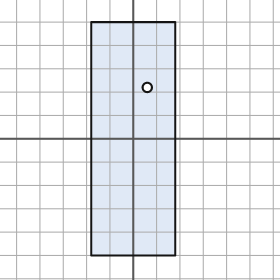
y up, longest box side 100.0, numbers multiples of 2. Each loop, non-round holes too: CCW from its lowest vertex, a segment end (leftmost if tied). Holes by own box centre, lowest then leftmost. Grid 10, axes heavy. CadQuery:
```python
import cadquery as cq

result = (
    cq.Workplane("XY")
    .moveTo(-18.0, -50.0)
    .lineTo(18.0, -50.0)
    .lineTo(18.0, 50.0)
    .lineTo(-18.0, 50.0)
    .close()
    .moveTo(6.0, 22.0)
    .circle(2.0)
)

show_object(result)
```